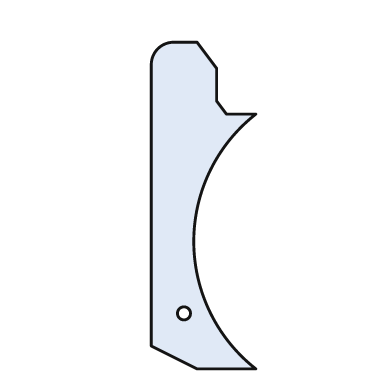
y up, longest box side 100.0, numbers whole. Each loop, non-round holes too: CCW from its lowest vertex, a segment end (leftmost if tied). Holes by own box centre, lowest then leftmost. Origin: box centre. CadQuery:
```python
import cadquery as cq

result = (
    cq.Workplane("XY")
    .moveTo(-2.0, -50.0)
    .lineTo(16.0, -50.0)
    .threePointArc((-3.0, -11.0), (16.0, 28.0))
    .lineTo(7.0, 28.0)
    .lineTo(4.0, 32.0)
    .lineTo(4.0, 42.0)
    .lineTo(-2.0, 50.0)
    .lineTo(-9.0, 50.0)
    .threePointArc((-14.0, 48.0), (-16.0, 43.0))
    .lineTo(-16.0, -43.0)
    .close()
    .moveTo(-6.0, -33.0)
    .circle(2.0)
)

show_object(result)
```